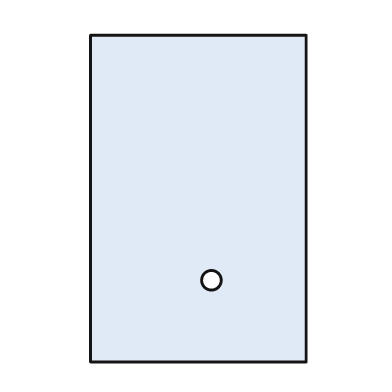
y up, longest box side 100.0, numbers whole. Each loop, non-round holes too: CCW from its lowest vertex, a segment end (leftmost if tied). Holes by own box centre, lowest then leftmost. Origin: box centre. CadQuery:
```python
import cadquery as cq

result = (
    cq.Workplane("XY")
    .moveTo(-33.0, -50.0)
    .lineTo(33.0, -50.0)
    .lineTo(33.0, 50.0)
    .lineTo(-33.0, 50.0)
    .close()
    .moveTo(4.0, -25.0)
    .circle(3.0)
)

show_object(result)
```